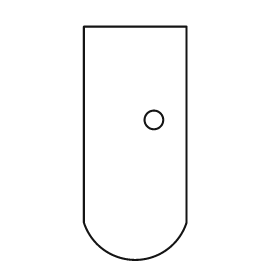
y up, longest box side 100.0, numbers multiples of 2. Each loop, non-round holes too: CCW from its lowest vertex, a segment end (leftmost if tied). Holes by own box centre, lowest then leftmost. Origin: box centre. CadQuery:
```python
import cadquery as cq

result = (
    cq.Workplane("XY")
    .moveTo(-22.0, -34.0)
    .threePointArc((0.0, -50.0), (22.0, -34.0))
    .lineTo(22.0, 50.0)
    .lineTo(-22.0, 50.0)
    .close()
    .moveTo(8.0, 10.0)
    .circle(4.0)
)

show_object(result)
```